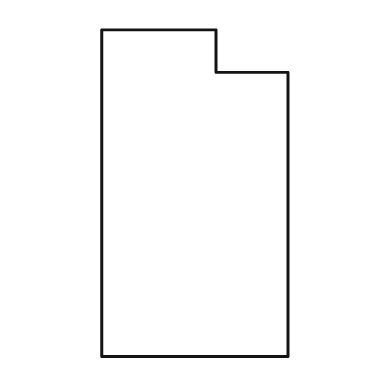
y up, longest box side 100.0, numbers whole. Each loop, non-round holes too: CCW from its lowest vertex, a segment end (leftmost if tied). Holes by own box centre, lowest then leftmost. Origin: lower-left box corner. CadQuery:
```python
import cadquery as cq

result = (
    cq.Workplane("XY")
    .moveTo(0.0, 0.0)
    .lineTo(57.0, 0.0)
    .lineTo(57.0, 87.0)
    .lineTo(35.0, 87.0)
    .lineTo(35.0, 100.0)
    .lineTo(0.0, 100.0)
    .close()
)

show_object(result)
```